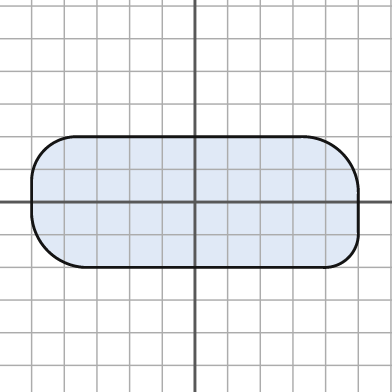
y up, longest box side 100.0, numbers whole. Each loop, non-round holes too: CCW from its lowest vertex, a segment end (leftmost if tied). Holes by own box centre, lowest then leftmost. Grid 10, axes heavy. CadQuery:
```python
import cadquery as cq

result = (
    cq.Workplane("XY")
    .moveTo(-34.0, -20.0)
    .lineTo(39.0, -20.0)
    .threePointArc((47.0, -17.0), (50.0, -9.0))
    .lineTo(50.0, 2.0)
    .threePointArc((45.0, 15.0), (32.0, 20.0))
    .lineTo(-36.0, 20.0)
    .threePointArc((-46.0, 16.0), (-50.0, 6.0))
    .lineTo(-50.0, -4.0)
    .threePointArc((-45.0, -15.0), (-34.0, -20.0))
    .close()
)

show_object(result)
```